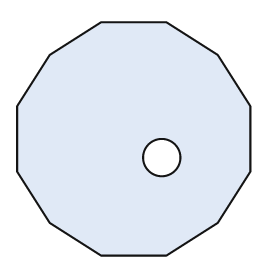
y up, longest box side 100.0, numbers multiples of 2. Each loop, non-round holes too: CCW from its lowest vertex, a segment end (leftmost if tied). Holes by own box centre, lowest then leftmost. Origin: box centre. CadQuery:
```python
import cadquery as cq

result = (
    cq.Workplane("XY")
    .moveTo(-14.0, -50.0)
    .lineTo(14.0, -50.0)
    .lineTo(36.0, -36.0)
    .lineTo(50.0, -14.0)
    .lineTo(50.0, 14.0)
    .lineTo(36.0, 36.0)
    .lineTo(14.0, 50.0)
    .lineTo(-14.0, 50.0)
    .lineTo(-36.0, 36.0)
    .lineTo(-50.0, 14.0)
    .lineTo(-50.0, -14.0)
    .lineTo(-36.0, -36.0)
    .close()
    .moveTo(12.0, -8.0)
    .circle(8.0)
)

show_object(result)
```